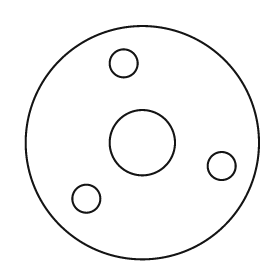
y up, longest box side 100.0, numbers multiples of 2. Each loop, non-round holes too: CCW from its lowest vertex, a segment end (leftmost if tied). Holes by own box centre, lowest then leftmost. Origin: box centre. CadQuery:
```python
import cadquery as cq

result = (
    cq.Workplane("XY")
    .moveTo(0.0, 0.0)
    .circle(50.0)
    .moveTo(-24.0, -24.0)
    .circle(6.0)
    .moveTo(34.0, -10.0)
    .circle(6.0)
    .moveTo(0.0, 0.0)
    .circle(14.0)
    .moveTo(-8.0, 34.0)
    .circle(6.0)
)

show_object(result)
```